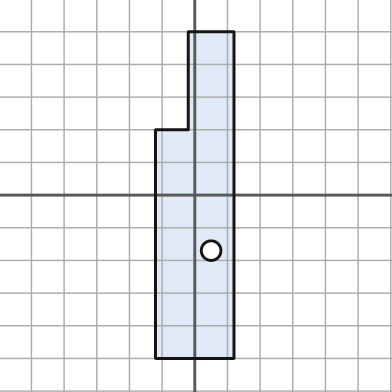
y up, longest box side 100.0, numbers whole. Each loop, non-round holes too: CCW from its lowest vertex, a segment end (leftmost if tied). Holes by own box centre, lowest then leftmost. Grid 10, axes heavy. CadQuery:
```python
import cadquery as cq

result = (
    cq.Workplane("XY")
    .moveTo(-12.0, -50.0)
    .lineTo(12.0, -50.0)
    .lineTo(12.0, 50.0)
    .lineTo(-2.0, 50.0)
    .lineTo(-2.0, 20.0)
    .lineTo(-12.0, 20.0)
    .close()
    .moveTo(5.0, -17.0)
    .circle(3.0)
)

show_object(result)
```